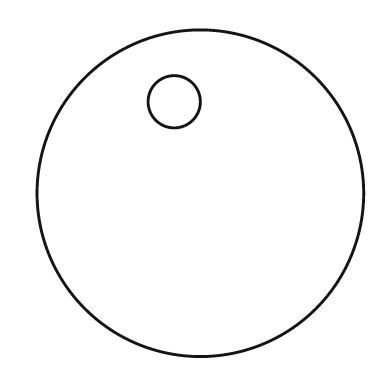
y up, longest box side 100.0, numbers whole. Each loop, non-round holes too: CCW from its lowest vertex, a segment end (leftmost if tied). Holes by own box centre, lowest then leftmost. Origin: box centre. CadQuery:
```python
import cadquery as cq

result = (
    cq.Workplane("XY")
    .moveTo(0.0, 0.0)
    .circle(50.0)
    .moveTo(-8.0, 28.0)
    .circle(8.0)
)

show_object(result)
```